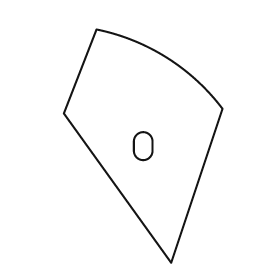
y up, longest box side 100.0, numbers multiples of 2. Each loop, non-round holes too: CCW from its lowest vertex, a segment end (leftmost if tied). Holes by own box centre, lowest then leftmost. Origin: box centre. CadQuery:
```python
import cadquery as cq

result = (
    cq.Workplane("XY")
    .moveTo(12.0, -50.0)
    .lineTo(34.0, 16.0)
    .threePointArc((10.0, 38.0), (-20.0, 50.0))
    .lineTo(-34.0, 14.0)
    .close()
    .moveTo(-4.0, -2.0)
    .threePointArc((0.0, -6.0), (4.0, -2.0))
    .lineTo(4.0, 2.0)
    .threePointArc((0.0, 6.0), (-4.0, 2.0))
    .close()
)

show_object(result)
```